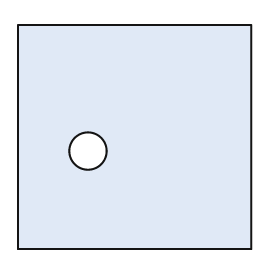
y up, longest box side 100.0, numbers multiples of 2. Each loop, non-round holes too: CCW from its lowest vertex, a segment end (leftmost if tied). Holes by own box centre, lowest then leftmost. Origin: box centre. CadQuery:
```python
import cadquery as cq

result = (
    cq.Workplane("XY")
    .moveTo(-50.0, -48.0)
    .lineTo(50.0, -48.0)
    .lineTo(50.0, 48.0)
    .lineTo(-50.0, 48.0)
    .close()
    .moveTo(-20.0, -6.0)
    .circle(8.0)
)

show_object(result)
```